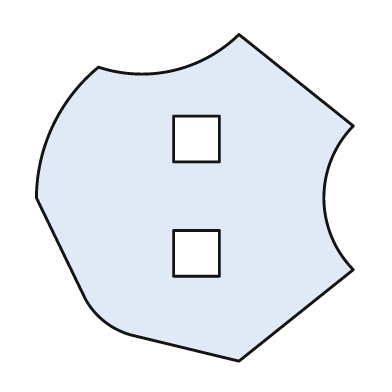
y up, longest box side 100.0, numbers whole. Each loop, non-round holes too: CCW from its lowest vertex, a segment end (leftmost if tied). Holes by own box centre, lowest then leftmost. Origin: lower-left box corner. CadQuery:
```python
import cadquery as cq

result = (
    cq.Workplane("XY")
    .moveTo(62.0, 0.0)
    .lineTo(97.0, 28.0)
    .threePointArc((88.0, 50.0), (97.0, 72.0))
    .lineTo(62.0, 100.0)
    .threePointArc((42.0, 89.0), (19.0, 90.0))
    .threePointArc((5.0, 72.0), (0.0, 50.0))
    .lineTo(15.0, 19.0)
    .threePointArc((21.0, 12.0), (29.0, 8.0))
    .close()
    .moveTo(42.0, 26.0)
    .lineTo(56.0, 26.0)
    .lineTo(56.0, 40.0)
    .lineTo(42.0, 40.0)
    .close()
    .moveTo(42.0, 61.0)
    .lineTo(56.0, 61.0)
    .lineTo(56.0, 75.0)
    .lineTo(42.0, 75.0)
    .close()
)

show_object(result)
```